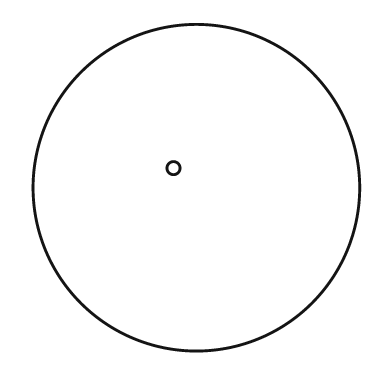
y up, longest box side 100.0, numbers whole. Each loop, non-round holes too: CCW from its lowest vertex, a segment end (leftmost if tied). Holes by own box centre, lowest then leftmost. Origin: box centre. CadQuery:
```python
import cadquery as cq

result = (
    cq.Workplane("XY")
    .moveTo(0.0, 0.0)
    .circle(50.0)
    .moveTo(-7.0, 6.0)
    .circle(2.0)
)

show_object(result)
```